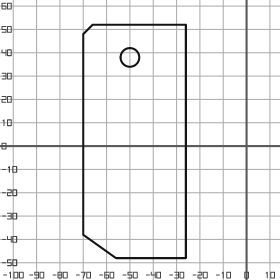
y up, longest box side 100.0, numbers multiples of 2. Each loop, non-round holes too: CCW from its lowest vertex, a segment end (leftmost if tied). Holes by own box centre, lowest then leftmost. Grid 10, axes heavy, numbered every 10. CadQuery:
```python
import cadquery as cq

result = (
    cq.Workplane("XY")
    .moveTo(-56.0, -48.0)
    .lineTo(-26.0, -48.0)
    .lineTo(-26.0, 52.0)
    .lineTo(-66.0, 52.0)
    .lineTo(-70.0, 48.0)
    .lineTo(-70.0, -38.0)
    .close()
    .moveTo(-50.0, 38.0)
    .circle(4.0)
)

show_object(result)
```